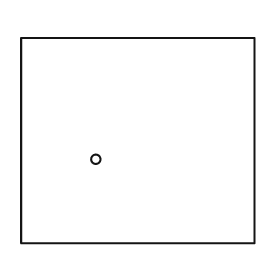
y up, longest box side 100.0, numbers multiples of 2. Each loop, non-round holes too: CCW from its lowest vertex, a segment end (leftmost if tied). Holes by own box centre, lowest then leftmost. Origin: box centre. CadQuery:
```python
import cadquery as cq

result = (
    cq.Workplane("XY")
    .moveTo(-50.0, -44.0)
    .lineTo(50.0, -44.0)
    .lineTo(50.0, 44.0)
    .lineTo(-50.0, 44.0)
    .close()
    .moveTo(-18.0, -8.0)
    .circle(2.0)
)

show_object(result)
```